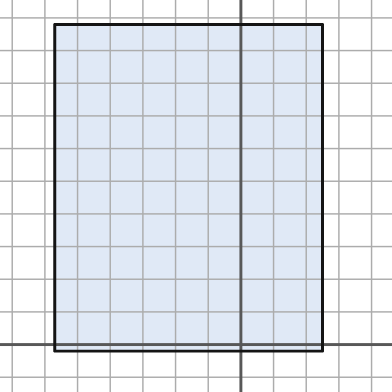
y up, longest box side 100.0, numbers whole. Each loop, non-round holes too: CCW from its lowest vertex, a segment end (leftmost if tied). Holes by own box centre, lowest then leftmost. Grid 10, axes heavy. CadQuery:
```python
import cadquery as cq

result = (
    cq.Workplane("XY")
    .moveTo(-57.0, -2.0)
    .lineTo(25.0, -2.0)
    .lineTo(25.0, 98.0)
    .lineTo(-57.0, 98.0)
    .close()
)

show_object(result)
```